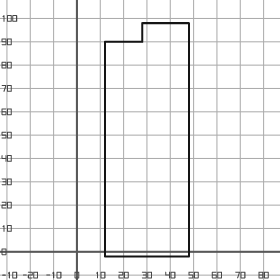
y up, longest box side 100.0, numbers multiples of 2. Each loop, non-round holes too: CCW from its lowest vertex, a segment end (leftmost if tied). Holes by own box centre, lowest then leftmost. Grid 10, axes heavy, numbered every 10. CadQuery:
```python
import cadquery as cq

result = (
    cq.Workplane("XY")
    .moveTo(12.0, -2.0)
    .lineTo(48.0, -2.0)
    .lineTo(48.0, 98.0)
    .lineTo(28.0, 98.0)
    .lineTo(28.0, 90.0)
    .lineTo(12.0, 90.0)
    .close()
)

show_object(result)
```